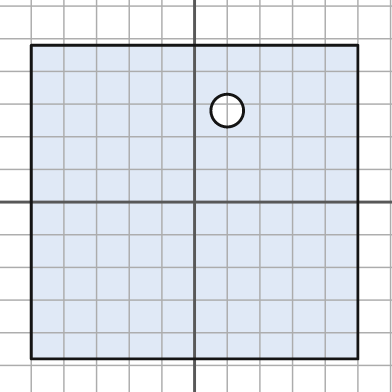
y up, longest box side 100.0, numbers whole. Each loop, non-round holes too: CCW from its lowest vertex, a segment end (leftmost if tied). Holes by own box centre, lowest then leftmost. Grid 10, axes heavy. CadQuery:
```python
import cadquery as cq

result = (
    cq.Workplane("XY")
    .moveTo(-50.0, -48.0)
    .lineTo(50.0, -48.0)
    .lineTo(50.0, 48.0)
    .lineTo(-50.0, 48.0)
    .close()
    .moveTo(10.0, 28.0)
    .circle(5.0)
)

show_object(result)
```